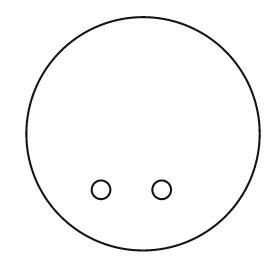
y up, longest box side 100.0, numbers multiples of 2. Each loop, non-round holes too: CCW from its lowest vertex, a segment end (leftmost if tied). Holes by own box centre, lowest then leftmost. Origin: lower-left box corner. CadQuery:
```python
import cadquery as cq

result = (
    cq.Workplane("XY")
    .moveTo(50.0, 50.0)
    .circle(50.0)
    .moveTo(32.0, 26.0)
    .circle(4.0)
    .moveTo(58.0, 26.0)
    .circle(4.0)
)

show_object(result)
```